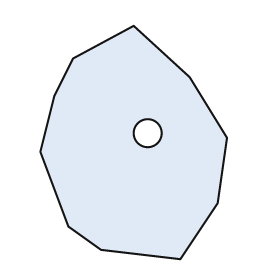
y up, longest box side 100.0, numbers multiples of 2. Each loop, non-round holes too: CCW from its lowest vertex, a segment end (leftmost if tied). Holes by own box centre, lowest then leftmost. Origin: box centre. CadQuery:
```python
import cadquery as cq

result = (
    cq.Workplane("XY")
    .moveTo(20.0, -50.0)
    .lineTo(36.0, -26.0)
    .lineTo(40.0, 2.0)
    .lineTo(24.0, 28.0)
    .lineTo(0.0, 50.0)
    .lineTo(-26.0, 36.0)
    .lineTo(-34.0, 20.0)
    .lineTo(-40.0, -4.0)
    .lineTo(-28.0, -36.0)
    .lineTo(-14.0, -46.0)
    .close()
    .moveTo(6.0, 4.0)
    .circle(6.0)
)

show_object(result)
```